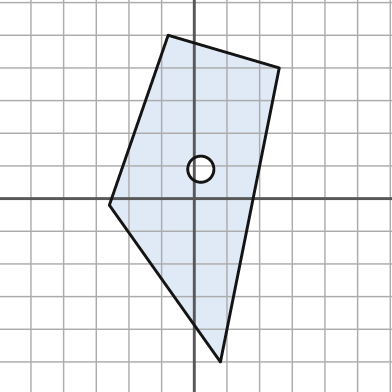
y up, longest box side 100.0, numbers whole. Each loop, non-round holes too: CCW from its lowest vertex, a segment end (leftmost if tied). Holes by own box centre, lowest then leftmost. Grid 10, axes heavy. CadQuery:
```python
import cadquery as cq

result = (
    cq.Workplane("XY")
    .moveTo(8.0, -50.0)
    .lineTo(26.0, 40.0)
    .lineTo(-8.0, 50.0)
    .lineTo(-26.0, -2.0)
    .close()
    .moveTo(2.0, 9.0)
    .circle(4.0)
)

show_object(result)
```